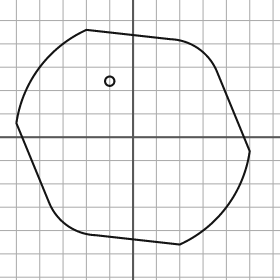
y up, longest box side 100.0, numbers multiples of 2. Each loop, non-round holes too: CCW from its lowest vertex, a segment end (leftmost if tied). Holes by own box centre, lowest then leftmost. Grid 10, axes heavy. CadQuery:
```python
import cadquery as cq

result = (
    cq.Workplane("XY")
    .moveTo(20.0, -46.0)
    .threePointArc((40.0, -30.0), (50.0, -6.0))
    .lineTo(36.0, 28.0)
    .threePointArc((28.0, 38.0), (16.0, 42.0))
    .lineTo(-20.0, 46.0)
    .threePointArc((-40.0, 30.0), (-50.0, 6.0))
    .lineTo(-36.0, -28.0)
    .threePointArc((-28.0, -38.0), (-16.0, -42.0))
    .close()
    .moveTo(-10.0, 24.0)
    .circle(2.0)
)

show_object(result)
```